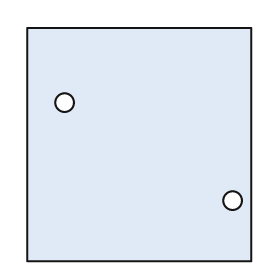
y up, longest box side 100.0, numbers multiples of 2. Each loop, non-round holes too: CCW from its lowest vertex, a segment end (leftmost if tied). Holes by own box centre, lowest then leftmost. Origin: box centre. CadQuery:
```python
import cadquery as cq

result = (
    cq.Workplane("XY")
    .moveTo(-48.0, -50.0)
    .lineTo(48.0, -50.0)
    .lineTo(48.0, 50.0)
    .lineTo(-48.0, 50.0)
    .close()
    .moveTo(40.0, -24.0)
    .circle(4.0)
    .moveTo(-32.0, 18.0)
    .circle(4.0)
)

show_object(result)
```